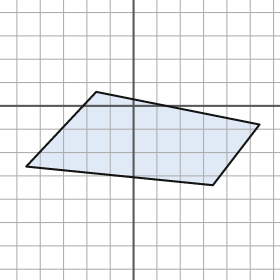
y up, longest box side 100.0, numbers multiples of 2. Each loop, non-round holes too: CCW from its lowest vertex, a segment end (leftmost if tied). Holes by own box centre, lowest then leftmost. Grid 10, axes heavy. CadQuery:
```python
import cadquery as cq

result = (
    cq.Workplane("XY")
    .moveTo(34.0, -34.0)
    .lineTo(54.0, -8.0)
    .lineTo(-16.0, 6.0)
    .lineTo(-46.0, -26.0)
    .close()
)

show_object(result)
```